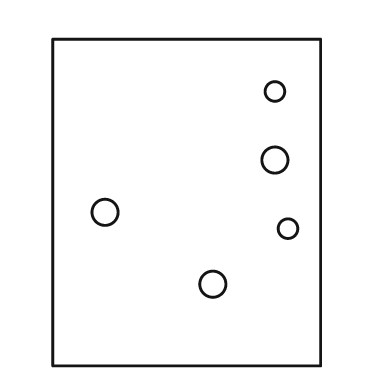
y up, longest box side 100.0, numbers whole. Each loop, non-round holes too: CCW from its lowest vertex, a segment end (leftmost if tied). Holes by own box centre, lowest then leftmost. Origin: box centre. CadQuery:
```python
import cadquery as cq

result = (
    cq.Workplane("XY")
    .moveTo(-41.0, -50.0)
    .lineTo(41.0, -50.0)
    .lineTo(41.0, 50.0)
    .lineTo(-41.0, 50.0)
    .close()
    .moveTo(8.0, -25.0)
    .circle(4.0)
    .moveTo(31.0, -8.0)
    .circle(3.0)
    .moveTo(-25.0, -3.0)
    .circle(4.0)
    .moveTo(27.0, 13.0)
    .circle(4.0)
    .moveTo(27.0, 34.0)
    .circle(3.0)
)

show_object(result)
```